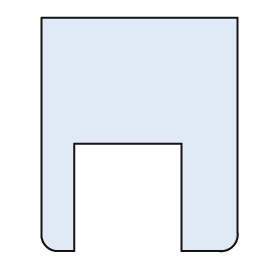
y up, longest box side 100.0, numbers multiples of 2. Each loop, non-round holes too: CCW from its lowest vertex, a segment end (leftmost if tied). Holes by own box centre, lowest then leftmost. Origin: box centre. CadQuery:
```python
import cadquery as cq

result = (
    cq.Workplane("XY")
    .moveTo(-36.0, -50.0)
    .lineTo(-28.0, -50.0)
    .lineTo(-28.0, -4.0)
    .lineTo(18.0, -4.0)
    .lineTo(18.0, -50.0)
    .lineTo(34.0, -50.0)
    .threePointArc((40.0, -48.0), (42.0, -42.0))
    .lineTo(42.0, 50.0)
    .lineTo(-42.0, 50.0)
    .lineTo(-42.0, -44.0)
    .threePointArc((-40.0, -48.0), (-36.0, -50.0))
    .close()
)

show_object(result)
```